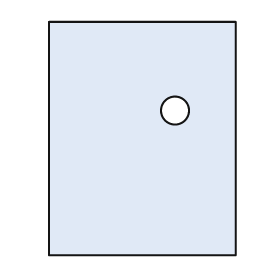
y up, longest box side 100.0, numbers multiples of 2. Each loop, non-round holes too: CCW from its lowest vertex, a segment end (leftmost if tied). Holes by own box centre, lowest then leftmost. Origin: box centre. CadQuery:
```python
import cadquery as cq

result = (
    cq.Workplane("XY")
    .moveTo(-40.0, -50.0)
    .lineTo(40.0, -50.0)
    .lineTo(40.0, 50.0)
    .lineTo(-40.0, 50.0)
    .close()
    .moveTo(14.0, 12.0)
    .circle(6.0)
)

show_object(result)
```